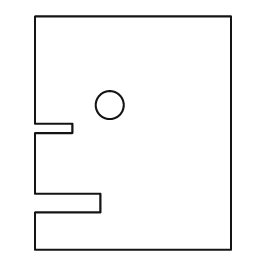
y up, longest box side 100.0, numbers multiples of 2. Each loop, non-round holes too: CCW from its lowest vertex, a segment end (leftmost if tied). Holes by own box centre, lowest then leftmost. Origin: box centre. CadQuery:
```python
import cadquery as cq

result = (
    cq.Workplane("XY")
    .moveTo(-42.0, -50.0)
    .lineTo(42.0, -50.0)
    .lineTo(42.0, 50.0)
    .lineTo(-42.0, 50.0)
    .lineTo(-42.0, 4.0)
    .lineTo(-26.0, 4.0)
    .lineTo(-26.0, 0.0)
    .lineTo(-42.0, 0.0)
    .lineTo(-42.0, -26.0)
    .lineTo(-14.0, -26.0)
    .lineTo(-14.0, -34.0)
    .lineTo(-42.0, -34.0)
    .close()
    .moveTo(-10.0, 12.0)
    .circle(6.0)
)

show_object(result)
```